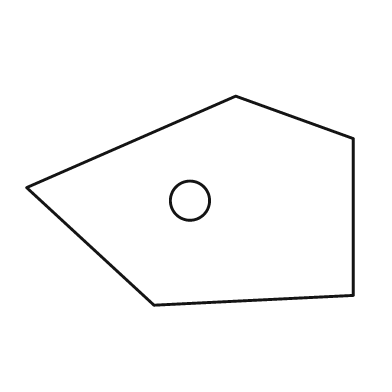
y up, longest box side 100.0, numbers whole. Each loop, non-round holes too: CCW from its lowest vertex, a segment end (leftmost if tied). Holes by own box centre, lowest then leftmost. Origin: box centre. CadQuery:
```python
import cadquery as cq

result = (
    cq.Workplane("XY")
    .moveTo(-11.0, -32.0)
    .lineTo(50.0, -29.0)
    .lineTo(50.0, 19.0)
    .lineTo(14.0, 32.0)
    .lineTo(-50.0, 4.0)
    .close()
    .moveTo(0.0, 0.0)
    .circle(6.0)
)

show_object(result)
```